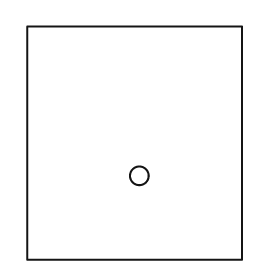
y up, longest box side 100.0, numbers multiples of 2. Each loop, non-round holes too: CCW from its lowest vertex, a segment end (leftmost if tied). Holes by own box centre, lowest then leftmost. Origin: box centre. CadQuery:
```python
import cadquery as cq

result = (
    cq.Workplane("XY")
    .moveTo(-46.0, -50.0)
    .lineTo(46.0, -50.0)
    .lineTo(46.0, 50.0)
    .lineTo(-46.0, 50.0)
    .close()
    .moveTo(2.0, -14.0)
    .circle(4.0)
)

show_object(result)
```